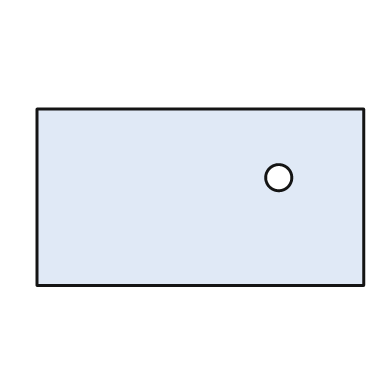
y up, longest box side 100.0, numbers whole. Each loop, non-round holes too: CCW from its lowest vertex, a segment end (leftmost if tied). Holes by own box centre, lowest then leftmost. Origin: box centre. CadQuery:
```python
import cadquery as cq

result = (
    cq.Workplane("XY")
    .moveTo(-50.0, -27.0)
    .lineTo(50.0, -27.0)
    .lineTo(50.0, 27.0)
    .lineTo(-50.0, 27.0)
    .close()
    .moveTo(24.0, 6.0)
    .circle(4.0)
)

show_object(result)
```